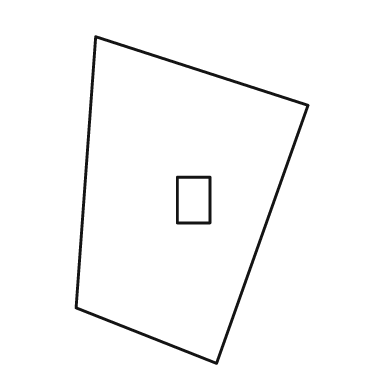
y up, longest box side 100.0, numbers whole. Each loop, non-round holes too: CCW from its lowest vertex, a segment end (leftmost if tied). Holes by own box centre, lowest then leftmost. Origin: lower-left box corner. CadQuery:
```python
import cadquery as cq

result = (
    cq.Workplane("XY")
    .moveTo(43.0, 0.0)
    .lineTo(71.0, 79.0)
    .lineTo(6.0, 100.0)
    .lineTo(0.0, 17.0)
    .close()
    .moveTo(31.0, 43.0)
    .lineTo(41.0, 43.0)
    .lineTo(41.0, 57.0)
    .lineTo(31.0, 57.0)
    .close()
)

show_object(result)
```